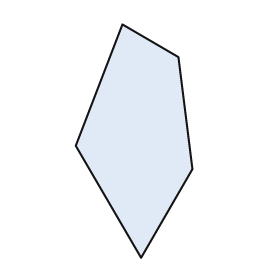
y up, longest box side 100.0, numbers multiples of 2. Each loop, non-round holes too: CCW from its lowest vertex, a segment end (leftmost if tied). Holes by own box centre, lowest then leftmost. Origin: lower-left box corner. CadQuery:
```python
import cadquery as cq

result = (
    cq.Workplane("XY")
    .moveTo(28.0, 0.0)
    .lineTo(50.0, 38.0)
    .lineTo(44.0, 86.0)
    .lineTo(20.0, 100.0)
    .lineTo(0.0, 48.0)
    .close()
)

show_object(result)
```